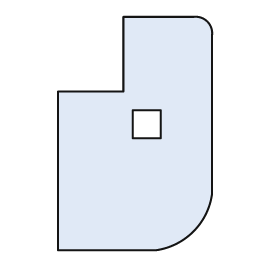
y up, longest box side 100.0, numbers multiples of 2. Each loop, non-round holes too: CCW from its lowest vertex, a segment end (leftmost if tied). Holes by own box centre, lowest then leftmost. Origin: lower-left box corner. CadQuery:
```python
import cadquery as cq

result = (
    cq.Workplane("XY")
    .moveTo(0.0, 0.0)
    .lineTo(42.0, 0.0)
    .threePointArc((58.0, 8.0), (66.0, 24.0))
    .lineTo(66.0, 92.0)
    .threePointArc((64.0, 98.0), (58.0, 100.0))
    .lineTo(28.0, 100.0)
    .lineTo(28.0, 68.0)
    .lineTo(0.0, 68.0)
    .close()
    .moveTo(32.0, 48.0)
    .lineTo(44.0, 48.0)
    .lineTo(44.0, 60.0)
    .lineTo(32.0, 60.0)
    .close()
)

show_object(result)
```